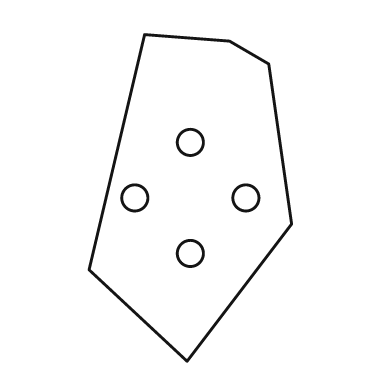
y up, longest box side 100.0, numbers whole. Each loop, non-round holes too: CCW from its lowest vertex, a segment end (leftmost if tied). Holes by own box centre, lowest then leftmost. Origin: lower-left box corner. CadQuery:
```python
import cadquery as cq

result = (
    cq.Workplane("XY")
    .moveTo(30.0, 0.0)
    .lineTo(62.0, 42.0)
    .lineTo(55.0, 91.0)
    .lineTo(43.0, 98.0)
    .lineTo(17.0, 100.0)
    .lineTo(0.0, 28.0)
    .close()
    .moveTo(31.0, 33.0)
    .circle(4.0)
    .moveTo(14.0, 50.0)
    .circle(4.0)
    .moveTo(48.0, 50.0)
    .circle(4.0)
    .moveTo(31.0, 67.0)
    .circle(4.0)
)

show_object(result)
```